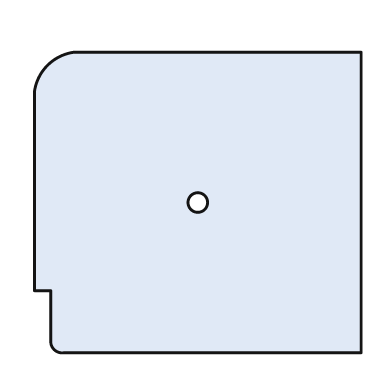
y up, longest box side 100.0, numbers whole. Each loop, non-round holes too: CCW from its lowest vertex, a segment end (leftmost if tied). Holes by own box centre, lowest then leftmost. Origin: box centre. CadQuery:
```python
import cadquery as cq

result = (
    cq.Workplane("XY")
    .moveTo(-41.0, -46.0)
    .lineTo(50.0, -46.0)
    .lineTo(50.0, 46.0)
    .lineTo(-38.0, 46.0)
    .threePointArc((-46.0, 42.0), (-50.0, 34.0))
    .lineTo(-50.0, -27.0)
    .lineTo(-45.0, -27.0)
    .lineTo(-45.0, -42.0)
    .threePointArc((-44.0, -45.0), (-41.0, -46.0))
    .close()
    .moveTo(0.0, 0.0)
    .circle(3.0)
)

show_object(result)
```